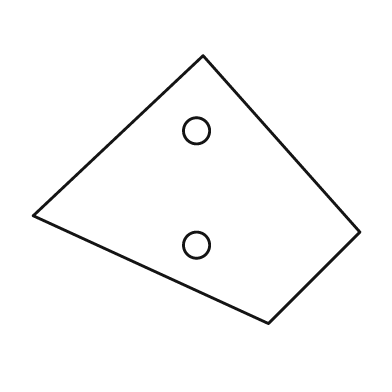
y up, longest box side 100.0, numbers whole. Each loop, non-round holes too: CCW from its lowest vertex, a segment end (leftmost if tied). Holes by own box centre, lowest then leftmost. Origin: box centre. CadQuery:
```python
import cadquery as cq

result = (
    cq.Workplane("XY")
    .moveTo(22.0, -41.0)
    .lineTo(50.0, -13.0)
    .lineTo(2.0, 41.0)
    .lineTo(-50.0, -8.0)
    .close()
    .moveTo(0.0, -17.0)
    .circle(4.0)
    .moveTo(0.0, 18.0)
    .circle(4.0)
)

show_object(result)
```